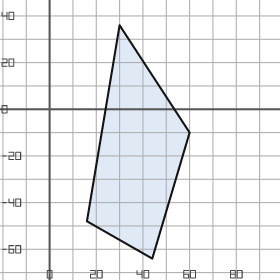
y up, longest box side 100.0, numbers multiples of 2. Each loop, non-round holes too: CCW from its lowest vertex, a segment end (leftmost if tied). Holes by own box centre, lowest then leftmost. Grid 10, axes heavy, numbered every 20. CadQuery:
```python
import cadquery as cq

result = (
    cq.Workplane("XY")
    .moveTo(44.0, -64.0)
    .lineTo(60.0, -10.0)
    .lineTo(30.0, 36.0)
    .lineTo(16.0, -48.0)
    .close()
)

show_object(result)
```